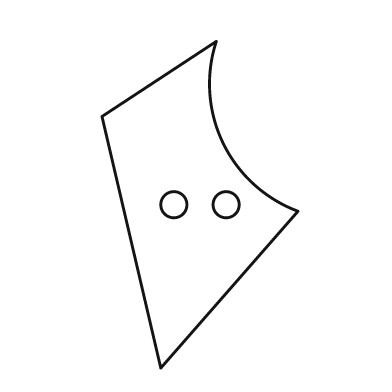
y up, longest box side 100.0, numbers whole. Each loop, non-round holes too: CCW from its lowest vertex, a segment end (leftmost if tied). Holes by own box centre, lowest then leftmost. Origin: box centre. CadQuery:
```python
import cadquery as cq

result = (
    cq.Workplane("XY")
    .moveTo(-12.0, -50.0)
    .lineTo(30.0, -2.0)
    .threePointArc((7.0, 19.0), (5.0, 50.0))
    .lineTo(-30.0, 27.0)
    .close()
    .moveTo(-8.0, 0.0)
    .circle(4.0)
    .moveTo(8.0, 0.0)
    .circle(4.0)
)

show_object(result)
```